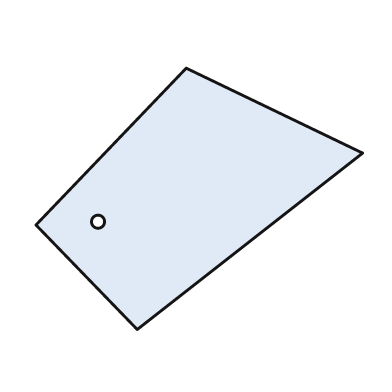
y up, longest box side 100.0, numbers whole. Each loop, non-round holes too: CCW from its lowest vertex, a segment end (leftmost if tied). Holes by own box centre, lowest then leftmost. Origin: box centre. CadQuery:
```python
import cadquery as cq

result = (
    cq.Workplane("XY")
    .moveTo(-19.0, -40.0)
    .lineTo(50.0, 14.0)
    .lineTo(-4.0, 40.0)
    .lineTo(-50.0, -8.0)
    .close()
    .moveTo(-31.0, -7.0)
    .circle(2.0)
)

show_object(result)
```